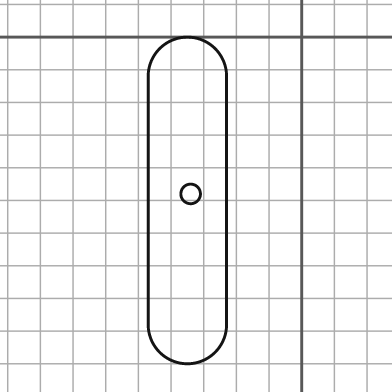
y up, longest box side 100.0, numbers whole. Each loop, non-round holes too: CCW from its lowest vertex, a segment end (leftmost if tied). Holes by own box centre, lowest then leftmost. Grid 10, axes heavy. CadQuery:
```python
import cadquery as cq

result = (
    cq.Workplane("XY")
    .moveTo(-47.0, -88.0)
    .threePointArc((-35.0, -100.0), (-23.0, -88.0))
    .lineTo(-23.0, -12.0)
    .threePointArc((-35.0, 0.0), (-47.0, -12.0))
    .close()
    .moveTo(-34.0, -48.0)
    .circle(3.0)
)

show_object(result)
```